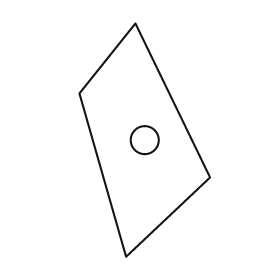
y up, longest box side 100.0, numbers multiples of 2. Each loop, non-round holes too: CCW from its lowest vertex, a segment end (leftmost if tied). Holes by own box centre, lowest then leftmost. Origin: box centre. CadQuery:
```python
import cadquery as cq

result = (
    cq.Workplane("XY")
    .moveTo(-8.0, -50.0)
    .lineTo(28.0, -16.0)
    .lineTo(-4.0, 50.0)
    .lineTo(-28.0, 20.0)
    .close()
    .moveTo(0.0, 0.0)
    .circle(6.0)
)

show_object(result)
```